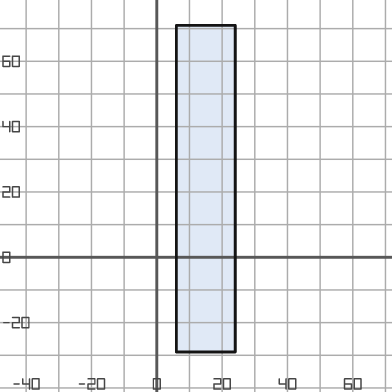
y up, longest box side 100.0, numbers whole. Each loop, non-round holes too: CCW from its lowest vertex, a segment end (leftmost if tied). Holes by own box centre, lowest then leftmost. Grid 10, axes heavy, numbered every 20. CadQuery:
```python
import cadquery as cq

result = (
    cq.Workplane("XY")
    .moveTo(6.0, -29.0)
    .lineTo(24.0, -29.0)
    .lineTo(24.0, 71.0)
    .lineTo(6.0, 71.0)
    .close()
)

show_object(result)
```